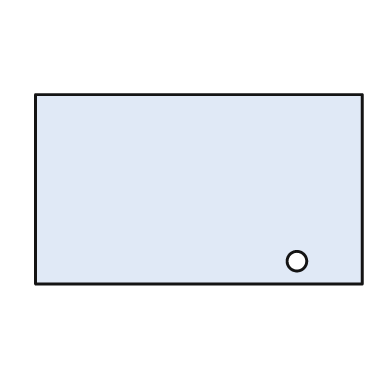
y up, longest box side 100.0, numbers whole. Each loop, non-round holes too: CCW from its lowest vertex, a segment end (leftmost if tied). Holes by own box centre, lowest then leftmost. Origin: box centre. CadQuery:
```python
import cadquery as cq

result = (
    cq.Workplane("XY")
    .moveTo(-50.0, -29.0)
    .lineTo(50.0, -29.0)
    .lineTo(50.0, 29.0)
    .lineTo(-50.0, 29.0)
    .close()
    .moveTo(30.0, -22.0)
    .circle(3.0)
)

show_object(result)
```